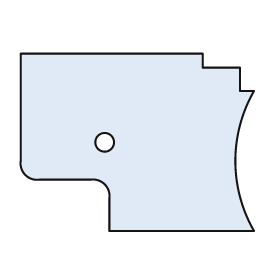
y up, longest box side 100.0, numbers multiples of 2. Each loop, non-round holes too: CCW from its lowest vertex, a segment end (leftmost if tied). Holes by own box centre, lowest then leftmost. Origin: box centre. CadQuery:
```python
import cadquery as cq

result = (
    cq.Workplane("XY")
    .moveTo(-12.0, -38.0)
    .lineTo(50.0, -38.0)
    .threePointArc((42.0, -8.0), (50.0, 22.0))
    .lineTo(44.0, 22.0)
    .lineTo(44.0, 32.0)
    .lineTo(28.0, 32.0)
    .lineTo(28.0, 38.0)
    .lineTo(-50.0, 38.0)
    .lineTo(-50.0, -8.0)
    .threePointArc((-48.0, -14.0), (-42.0, -16.0))
    .lineTo(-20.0, -16.0)
    .threePointArc((-14.0, -18.0), (-12.0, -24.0))
    .close()
    .moveTo(-14.0, 0.0)
    .circle(4.0)
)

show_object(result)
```